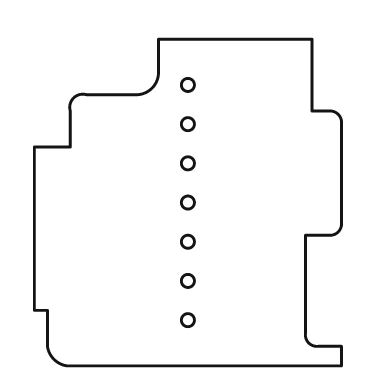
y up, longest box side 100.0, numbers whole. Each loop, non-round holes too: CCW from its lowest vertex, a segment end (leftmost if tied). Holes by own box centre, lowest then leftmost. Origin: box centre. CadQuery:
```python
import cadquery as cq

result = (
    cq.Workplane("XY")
    .moveTo(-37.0, -50.0)
    .lineTo(47.0, -50.0)
    .lineTo(47.0, -44.0)
    .lineTo(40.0, -44.0)
    .threePointArc((37.0, -43.0), (36.0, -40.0))
    .lineTo(36.0, -10.0)
    .lineTo(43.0, -10.0)
    .threePointArc((46.0, -9.0), (47.0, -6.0))
    .lineTo(47.0, 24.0)
    .threePointArc((46.0, 27.0), (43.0, 28.0))
    .lineTo(38.0, 28.0)
    .lineTo(38.0, 50.0)
    .lineTo(-9.0, 50.0)
    .lineTo(-9.0, 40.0)
    .threePointArc((-11.0, 35.0), (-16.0, 33.0))
    .lineTo(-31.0, 33.0)
    .threePointArc((-35.0, 32.0), (-36.0, 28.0))
    .lineTo(-36.0, 17.0)
    .lineTo(-47.0, 17.0)
    .lineTo(-47.0, -33.0)
    .lineTo(-43.0, -33.0)
    .lineTo(-43.0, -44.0)
    .threePointArc((-41.0, -48.0), (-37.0, -50.0))
    .close()
    .moveTo(0.0, -36.0)
    .circle(2.0)
    .moveTo(0.0, -24.0)
    .circle(2.0)
    .moveTo(0.0, -12.0)
    .circle(2.0)
    .moveTo(0.0, 0.0)
    .circle(2.0)
    .moveTo(0.0, 12.0)
    .circle(2.0)
    .moveTo(0.0, 24.0)
    .circle(2.0)
    .moveTo(0.0, 36.0)
    .circle(2.0)
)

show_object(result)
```